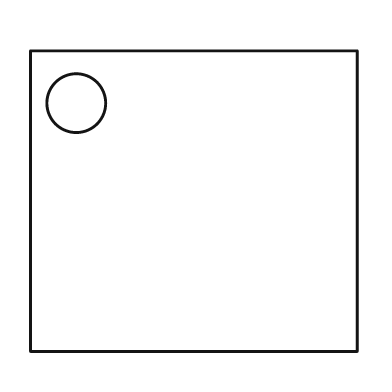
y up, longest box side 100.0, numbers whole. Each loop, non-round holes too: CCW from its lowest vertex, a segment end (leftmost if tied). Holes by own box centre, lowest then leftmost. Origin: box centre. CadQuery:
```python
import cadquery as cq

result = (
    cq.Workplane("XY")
    .moveTo(-50.0, -46.0)
    .lineTo(50.0, -46.0)
    .lineTo(50.0, 46.0)
    .lineTo(-50.0, 46.0)
    .close()
    .moveTo(-36.0, 30.0)
    .circle(9.0)
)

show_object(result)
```